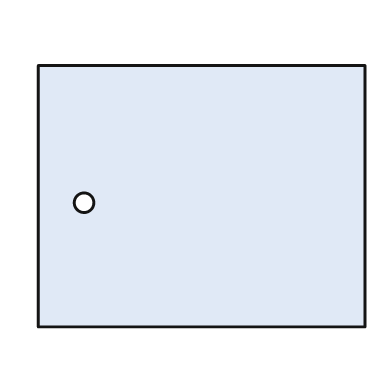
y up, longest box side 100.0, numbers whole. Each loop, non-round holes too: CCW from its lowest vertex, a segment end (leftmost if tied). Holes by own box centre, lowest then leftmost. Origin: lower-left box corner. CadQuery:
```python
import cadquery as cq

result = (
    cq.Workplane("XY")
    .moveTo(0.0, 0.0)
    .lineTo(100.0, 0.0)
    .lineTo(100.0, 80.0)
    .lineTo(0.0, 80.0)
    .close()
    .moveTo(14.0, 38.0)
    .circle(3.0)
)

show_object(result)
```